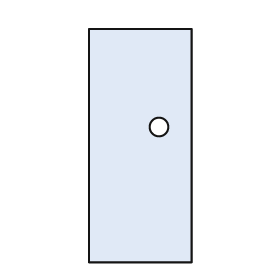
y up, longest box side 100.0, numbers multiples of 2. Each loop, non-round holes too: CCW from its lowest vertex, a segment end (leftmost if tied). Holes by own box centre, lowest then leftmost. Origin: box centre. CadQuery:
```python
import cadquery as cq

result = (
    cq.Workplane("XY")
    .moveTo(-22.0, -50.0)
    .lineTo(22.0, -50.0)
    .lineTo(22.0, 50.0)
    .lineTo(-22.0, 50.0)
    .close()
    .moveTo(8.0, 8.0)
    .circle(4.0)
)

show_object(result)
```